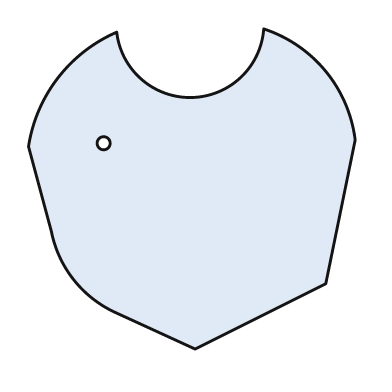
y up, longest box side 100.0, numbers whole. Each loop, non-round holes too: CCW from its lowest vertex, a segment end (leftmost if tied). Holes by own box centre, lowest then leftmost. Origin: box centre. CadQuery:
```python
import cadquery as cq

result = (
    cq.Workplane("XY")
    .moveTo(1.0, -49.0)
    .lineTo(41.0, -29.0)
    .lineTo(50.0, 15.0)
    .threePointArc((41.0, 36.0), (22.0, 49.0))
    .threePointArc((0.0, 28.0), (-23.0, 48.0))
    .threePointArc((-41.0, 34.0), (-50.0, 13.0))
    .lineTo(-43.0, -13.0)
    .threePointArc((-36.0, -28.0), (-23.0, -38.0))
    .close()
    .moveTo(-27.0, 14.0)
    .circle(2.0)
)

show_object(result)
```